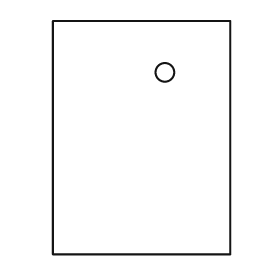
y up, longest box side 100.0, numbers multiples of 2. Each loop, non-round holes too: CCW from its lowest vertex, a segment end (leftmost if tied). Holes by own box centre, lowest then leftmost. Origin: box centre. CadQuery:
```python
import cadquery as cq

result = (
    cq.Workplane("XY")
    .moveTo(-38.0, -50.0)
    .lineTo(38.0, -50.0)
    .lineTo(38.0, 50.0)
    .lineTo(-38.0, 50.0)
    .close()
    .moveTo(10.0, 28.0)
    .circle(4.0)
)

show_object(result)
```